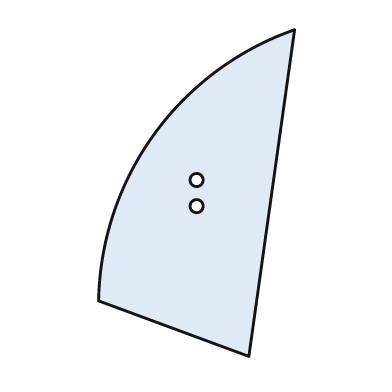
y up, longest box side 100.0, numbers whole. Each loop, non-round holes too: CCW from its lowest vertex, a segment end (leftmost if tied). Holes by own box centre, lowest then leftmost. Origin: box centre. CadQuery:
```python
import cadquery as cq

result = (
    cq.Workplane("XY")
    .moveTo(16.0, -50.0)
    .lineTo(30.0, 50.0)
    .threePointArc((-13.0, 18.0), (-30.0, -33.0))
    .close()
    .moveTo(0.0, -4.0)
    .circle(2.0)
    .moveTo(0.0, 4.0)
    .circle(2.0)
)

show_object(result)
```